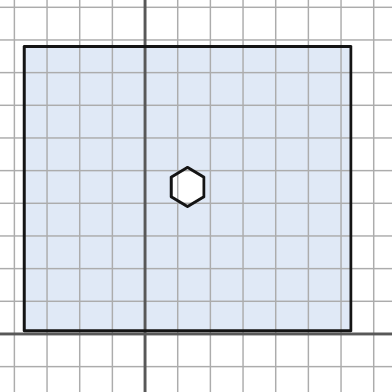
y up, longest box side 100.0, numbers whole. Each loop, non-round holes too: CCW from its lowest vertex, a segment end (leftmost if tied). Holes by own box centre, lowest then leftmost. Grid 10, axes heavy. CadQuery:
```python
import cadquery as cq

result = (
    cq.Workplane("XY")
    .moveTo(-37.0, 1.0)
    .lineTo(63.0, 1.0)
    .lineTo(63.0, 88.0)
    .lineTo(-37.0, 88.0)
    .close()
    .moveTo(13.0, 39.0)
    .lineTo(18.0, 42.0)
    .lineTo(18.0, 48.0)
    .lineTo(13.0, 51.0)
    .lineTo(8.0, 48.0)
    .lineTo(8.0, 42.0)
    .close()
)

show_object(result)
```